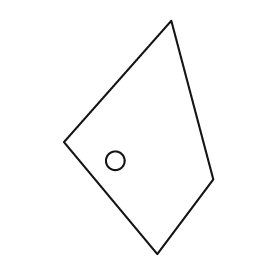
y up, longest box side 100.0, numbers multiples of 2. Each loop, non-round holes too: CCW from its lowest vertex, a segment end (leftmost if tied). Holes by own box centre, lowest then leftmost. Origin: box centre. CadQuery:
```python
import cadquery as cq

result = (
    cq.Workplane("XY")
    .moveTo(8.0, -50.0)
    .lineTo(32.0, -18.0)
    .lineTo(14.0, 50.0)
    .lineTo(-32.0, -2.0)
    .close()
    .moveTo(-10.0, -10.0)
    .circle(4.0)
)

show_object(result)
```